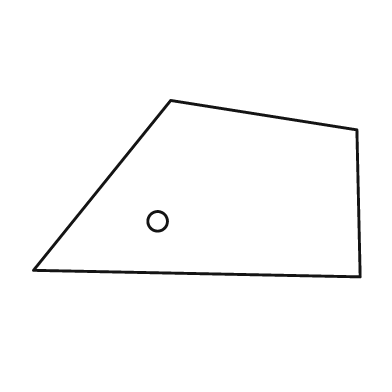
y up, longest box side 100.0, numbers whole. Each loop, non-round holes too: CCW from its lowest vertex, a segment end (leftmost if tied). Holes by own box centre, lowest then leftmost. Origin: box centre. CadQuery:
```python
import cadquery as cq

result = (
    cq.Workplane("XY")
    .moveTo(50.0, -27.0)
    .lineTo(49.0, 18.0)
    .lineTo(-8.0, 27.0)
    .lineTo(-50.0, -25.0)
    .close()
    .moveTo(-12.0, -10.0)
    .circle(3.0)
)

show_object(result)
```